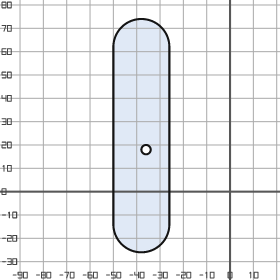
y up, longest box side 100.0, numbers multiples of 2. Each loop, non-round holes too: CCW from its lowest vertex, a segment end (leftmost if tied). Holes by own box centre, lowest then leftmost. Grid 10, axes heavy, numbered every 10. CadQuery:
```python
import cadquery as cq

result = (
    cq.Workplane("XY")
    .moveTo(-50.0, -14.0)
    .threePointArc((-38.0, -26.0), (-26.0, -14.0))
    .lineTo(-26.0, 62.0)
    .threePointArc((-38.0, 74.0), (-50.0, 62.0))
    .close()
    .moveTo(-36.0, 18.0)
    .circle(2.0)
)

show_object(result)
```